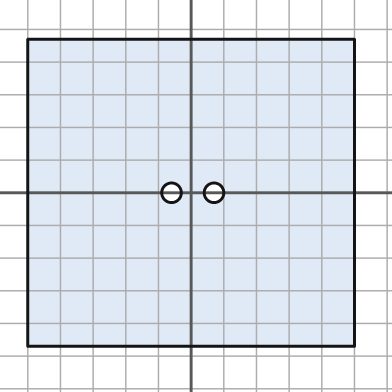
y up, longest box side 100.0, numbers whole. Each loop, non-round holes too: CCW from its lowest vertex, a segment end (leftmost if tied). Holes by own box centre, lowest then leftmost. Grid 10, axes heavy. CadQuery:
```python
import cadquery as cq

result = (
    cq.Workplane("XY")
    .moveTo(-50.0, -47.0)
    .lineTo(50.0, -47.0)
    .lineTo(50.0, 47.0)
    .lineTo(-50.0, 47.0)
    .close()
    .moveTo(-6.0, 0.0)
    .circle(3.0)
    .moveTo(7.0, 0.0)
    .circle(3.0)
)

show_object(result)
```